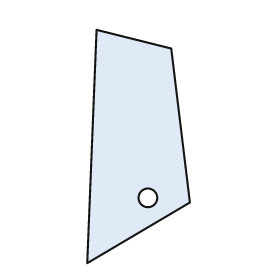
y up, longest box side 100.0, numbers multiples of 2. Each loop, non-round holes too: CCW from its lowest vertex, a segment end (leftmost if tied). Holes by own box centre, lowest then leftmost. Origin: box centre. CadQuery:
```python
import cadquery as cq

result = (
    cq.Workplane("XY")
    .moveTo(-22.0, -50.0)
    .lineTo(22.0, -24.0)
    .lineTo(14.0, 42.0)
    .lineTo(-18.0, 50.0)
    .close()
    .moveTo(4.0, -22.0)
    .circle(4.0)
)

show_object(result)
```